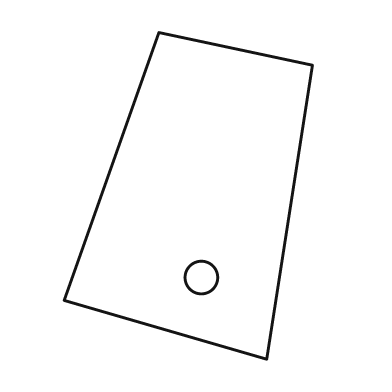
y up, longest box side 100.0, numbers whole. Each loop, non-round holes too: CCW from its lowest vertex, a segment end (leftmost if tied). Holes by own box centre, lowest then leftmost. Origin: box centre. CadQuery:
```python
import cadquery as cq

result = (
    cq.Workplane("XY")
    .moveTo(24.0, -50.0)
    .lineTo(38.0, 40.0)
    .lineTo(-9.0, 50.0)
    .lineTo(-38.0, -32.0)
    .close()
    .moveTo(4.0, -25.0)
    .circle(5.0)
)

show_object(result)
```